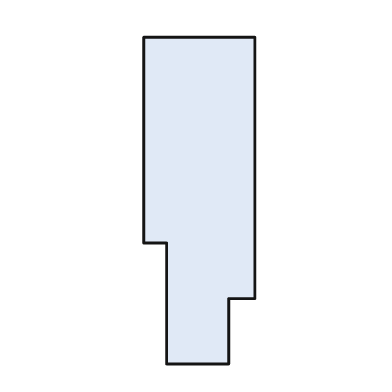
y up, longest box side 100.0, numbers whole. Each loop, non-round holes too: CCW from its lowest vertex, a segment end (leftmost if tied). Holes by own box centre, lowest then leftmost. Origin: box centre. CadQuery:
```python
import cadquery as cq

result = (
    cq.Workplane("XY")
    .moveTo(-10.0, -50.0)
    .lineTo(9.0, -50.0)
    .lineTo(9.0, -30.0)
    .lineTo(17.0, -30.0)
    .lineTo(17.0, 50.0)
    .lineTo(-17.0, 50.0)
    .lineTo(-17.0, -13.0)
    .lineTo(-10.0, -13.0)
    .close()
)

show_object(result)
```